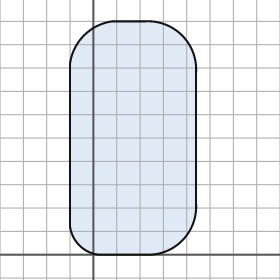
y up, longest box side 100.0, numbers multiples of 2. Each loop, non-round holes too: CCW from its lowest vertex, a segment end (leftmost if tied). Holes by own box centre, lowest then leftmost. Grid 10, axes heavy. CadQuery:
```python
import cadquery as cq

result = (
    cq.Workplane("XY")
    .moveTo(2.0, 0.0)
    .lineTo(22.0, 0.0)
    .threePointArc((38.0, 6.0), (44.0, 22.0))
    .lineTo(44.0, 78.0)
    .threePointArc((38.0, 94.0), (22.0, 100.0))
    .lineTo(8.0, 100.0)
    .threePointArc((-4.0, 94.0), (-10.0, 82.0))
    .lineTo(-10.0, 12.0)
    .threePointArc((-6.0, 4.0), (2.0, 0.0))
    .close()
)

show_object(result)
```